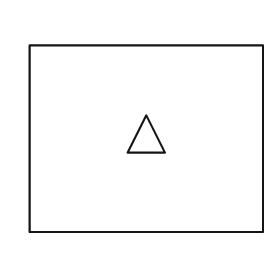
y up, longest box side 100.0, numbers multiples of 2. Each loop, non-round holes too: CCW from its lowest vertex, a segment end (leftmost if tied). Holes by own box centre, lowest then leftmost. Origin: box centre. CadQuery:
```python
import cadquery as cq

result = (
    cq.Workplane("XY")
    .moveTo(-50.0, -40.0)
    .lineTo(50.0, -40.0)
    .lineTo(50.0, 40.0)
    .lineTo(-50.0, 40.0)
    .close()
    .moveTo(-8.0, -6.0)
    .lineTo(8.0, -6.0)
    .lineTo(0.0, 10.0)
    .close()
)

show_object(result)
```